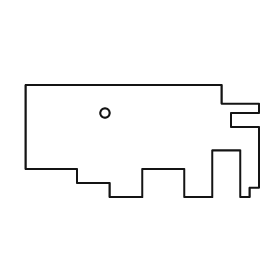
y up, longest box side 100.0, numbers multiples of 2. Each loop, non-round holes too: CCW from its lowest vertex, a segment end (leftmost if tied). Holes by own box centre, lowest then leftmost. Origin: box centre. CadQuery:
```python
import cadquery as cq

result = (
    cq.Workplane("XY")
    .moveTo(-14.0, -24.0)
    .lineTo(0.0, -24.0)
    .lineTo(0.0, -12.0)
    .lineTo(18.0, -12.0)
    .lineTo(18.0, -24.0)
    .lineTo(30.0, -24.0)
    .lineTo(30.0, -4.0)
    .lineTo(42.0, -4.0)
    .lineTo(42.0, -24.0)
    .lineTo(46.0, -24.0)
    .lineTo(46.0, -20.0)
    .lineTo(50.0, -20.0)
    .lineTo(50.0, 6.0)
    .lineTo(38.0, 6.0)
    .lineTo(38.0, 12.0)
    .lineTo(50.0, 12.0)
    .lineTo(50.0, 16.0)
    .lineTo(34.0, 16.0)
    .lineTo(34.0, 24.0)
    .lineTo(-50.0, 24.0)
    .lineTo(-50.0, -12.0)
    .lineTo(-28.0, -12.0)
    .lineTo(-28.0, -18.0)
    .lineTo(-14.0, -18.0)
    .close()
    .moveTo(-16.0, 12.0)
    .circle(2.0)
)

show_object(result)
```